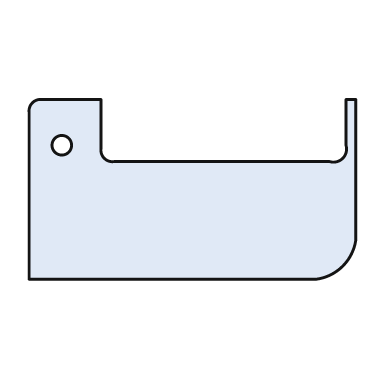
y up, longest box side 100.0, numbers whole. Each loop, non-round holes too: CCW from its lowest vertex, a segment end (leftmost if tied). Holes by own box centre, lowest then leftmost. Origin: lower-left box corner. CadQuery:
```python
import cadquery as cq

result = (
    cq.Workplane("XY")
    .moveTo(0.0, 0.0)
    .lineTo(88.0, 0.0)
    .threePointArc((96.0, 4.0), (100.0, 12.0))
    .lineTo(100.0, 55.0)
    .lineTo(97.0, 55.0)
    .lineTo(97.0, 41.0)
    .threePointArc((96.0, 37.0), (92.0, 36.0))
    .lineTo(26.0, 36.0)
    .threePointArc((23.0, 37.0), (22.0, 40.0))
    .lineTo(22.0, 55.0)
    .lineTo(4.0, 55.0)
    .threePointArc((1.0, 54.0), (0.0, 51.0))
    .close()
    .moveTo(10.0, 41.0)
    .circle(3.0)
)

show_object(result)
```